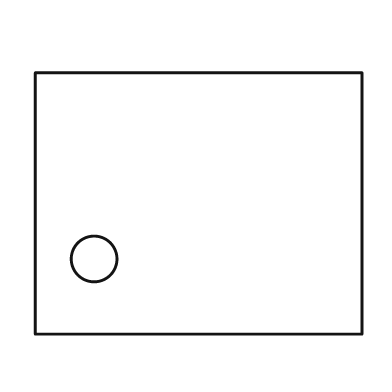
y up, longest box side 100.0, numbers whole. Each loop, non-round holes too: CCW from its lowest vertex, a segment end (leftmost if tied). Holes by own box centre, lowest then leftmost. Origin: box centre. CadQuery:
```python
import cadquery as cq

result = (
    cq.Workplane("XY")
    .moveTo(-50.0, -40.0)
    .lineTo(50.0, -40.0)
    .lineTo(50.0, 40.0)
    .lineTo(-50.0, 40.0)
    .close()
    .moveTo(-32.0, -17.0)
    .circle(7.0)
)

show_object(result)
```